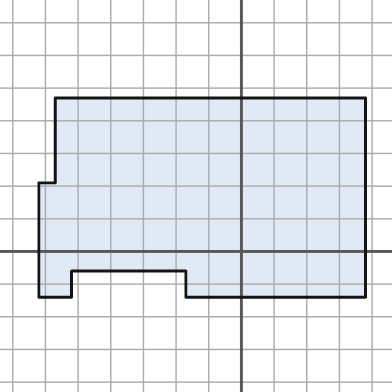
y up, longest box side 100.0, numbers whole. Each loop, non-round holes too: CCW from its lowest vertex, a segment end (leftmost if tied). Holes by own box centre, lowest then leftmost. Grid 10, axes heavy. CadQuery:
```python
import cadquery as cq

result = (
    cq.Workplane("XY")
    .moveTo(-62.0, -14.0)
    .lineTo(-52.0, -14.0)
    .lineTo(-52.0, -6.0)
    .lineTo(-17.0, -6.0)
    .lineTo(-17.0, -14.0)
    .lineTo(38.0, -14.0)
    .lineTo(38.0, 47.0)
    .lineTo(-57.0, 47.0)
    .lineTo(-57.0, 21.0)
    .lineTo(-62.0, 21.0)
    .close()
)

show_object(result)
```